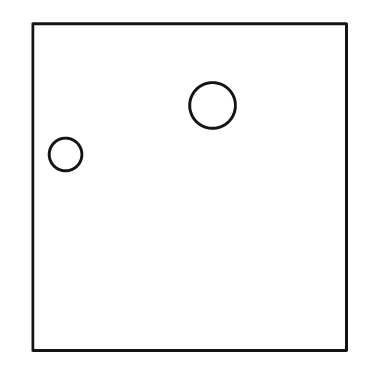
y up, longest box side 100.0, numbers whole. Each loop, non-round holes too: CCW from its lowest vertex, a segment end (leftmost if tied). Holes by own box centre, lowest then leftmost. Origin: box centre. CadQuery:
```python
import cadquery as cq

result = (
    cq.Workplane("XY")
    .moveTo(-48.0, -50.0)
    .lineTo(48.0, -50.0)
    .lineTo(48.0, 50.0)
    .lineTo(-48.0, 50.0)
    .close()
    .moveTo(-38.0, 10.0)
    .circle(5.0)
    .moveTo(7.0, 25.0)
    .circle(7.0)
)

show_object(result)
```